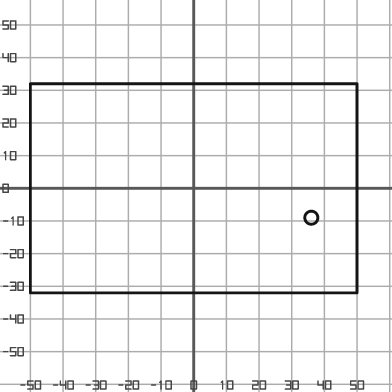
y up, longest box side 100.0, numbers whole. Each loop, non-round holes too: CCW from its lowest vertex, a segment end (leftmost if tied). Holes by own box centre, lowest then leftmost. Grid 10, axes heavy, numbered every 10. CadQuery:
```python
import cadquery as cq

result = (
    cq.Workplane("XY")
    .moveTo(-50.0, -32.0)
    .lineTo(50.0, -32.0)
    .lineTo(50.0, 32.0)
    .lineTo(-50.0, 32.0)
    .close()
    .moveTo(36.0, -9.0)
    .circle(2.0)
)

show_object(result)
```